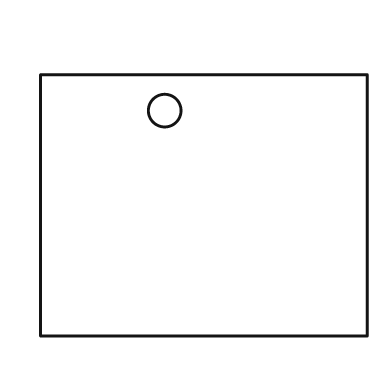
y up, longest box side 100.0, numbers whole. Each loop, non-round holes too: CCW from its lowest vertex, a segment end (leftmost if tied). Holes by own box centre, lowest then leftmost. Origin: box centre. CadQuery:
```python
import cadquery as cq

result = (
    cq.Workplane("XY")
    .moveTo(-50.0, -40.0)
    .lineTo(50.0, -40.0)
    .lineTo(50.0, 40.0)
    .lineTo(-50.0, 40.0)
    .close()
    .moveTo(-12.0, 29.0)
    .circle(5.0)
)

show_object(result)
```